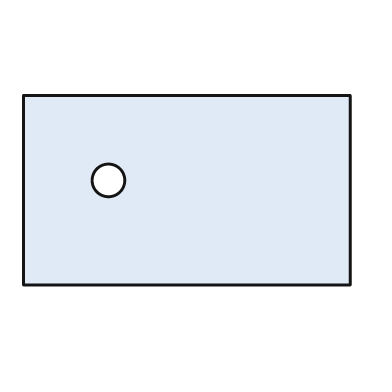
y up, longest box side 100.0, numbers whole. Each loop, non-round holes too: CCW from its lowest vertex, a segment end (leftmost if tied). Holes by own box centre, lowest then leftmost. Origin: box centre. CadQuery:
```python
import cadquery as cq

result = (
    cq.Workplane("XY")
    .moveTo(-50.0, -29.0)
    .lineTo(50.0, -29.0)
    .lineTo(50.0, 29.0)
    .lineTo(-50.0, 29.0)
    .close()
    .moveTo(-24.0, 3.0)
    .circle(5.0)
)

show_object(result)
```